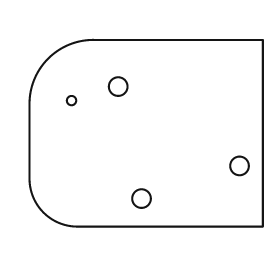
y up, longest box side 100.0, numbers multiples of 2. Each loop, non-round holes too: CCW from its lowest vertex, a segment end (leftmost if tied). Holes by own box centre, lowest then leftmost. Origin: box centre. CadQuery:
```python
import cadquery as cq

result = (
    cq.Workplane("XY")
    .moveTo(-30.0, -40.0)
    .lineTo(50.0, -40.0)
    .lineTo(50.0, 40.0)
    .lineTo(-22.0, 40.0)
    .threePointArc((-42.0, 32.0), (-50.0, 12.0))
    .lineTo(-50.0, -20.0)
    .threePointArc((-44.0, -34.0), (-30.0, -40.0))
    .close()
    .moveTo(-2.0, -28.0)
    .circle(4.0)
    .moveTo(40.0, -14.0)
    .circle(4.0)
    .moveTo(-32.0, 14.0)
    .circle(2.0)
    .moveTo(-12.0, 20.0)
    .circle(4.0)
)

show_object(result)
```